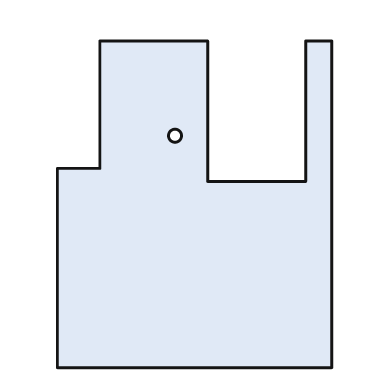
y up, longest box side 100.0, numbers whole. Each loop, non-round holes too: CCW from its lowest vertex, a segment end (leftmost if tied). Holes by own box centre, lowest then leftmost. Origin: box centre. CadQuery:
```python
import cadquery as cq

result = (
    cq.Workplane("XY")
    .moveTo(-42.0, -50.0)
    .lineTo(42.0, -50.0)
    .lineTo(42.0, 50.0)
    .lineTo(34.0, 50.0)
    .lineTo(34.0, 7.0)
    .lineTo(4.0, 7.0)
    .lineTo(4.0, 50.0)
    .lineTo(-29.0, 50.0)
    .lineTo(-29.0, 11.0)
    .lineTo(-42.0, 11.0)
    .close()
    .moveTo(-6.0, 21.0)
    .circle(2.0)
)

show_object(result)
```